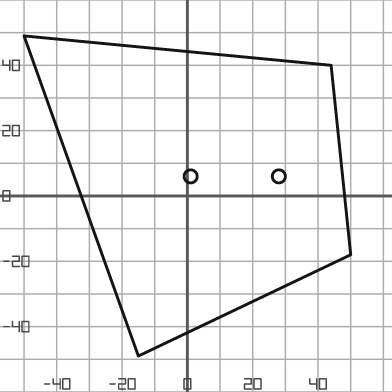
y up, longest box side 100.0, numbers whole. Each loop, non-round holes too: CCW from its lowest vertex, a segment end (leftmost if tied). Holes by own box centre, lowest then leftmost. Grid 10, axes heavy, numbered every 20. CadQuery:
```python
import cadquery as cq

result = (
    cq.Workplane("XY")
    .moveTo(-15.0, -49.0)
    .lineTo(50.0, -18.0)
    .lineTo(44.0, 40.0)
    .lineTo(-50.0, 49.0)
    .close()
    .moveTo(1.0, 6.0)
    .circle(2.0)
    .moveTo(28.0, 6.0)
    .circle(2.0)
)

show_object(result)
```